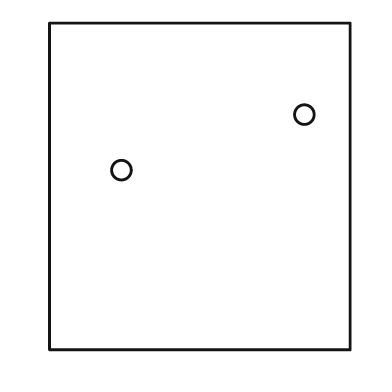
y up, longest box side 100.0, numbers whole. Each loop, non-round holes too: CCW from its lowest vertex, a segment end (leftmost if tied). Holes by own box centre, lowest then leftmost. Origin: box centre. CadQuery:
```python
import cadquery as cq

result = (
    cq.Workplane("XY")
    .moveTo(-46.0, -50.0)
    .lineTo(46.0, -50.0)
    .lineTo(46.0, 50.0)
    .lineTo(-46.0, 50.0)
    .close()
    .moveTo(-24.0, 5.0)
    .circle(3.0)
    .moveTo(32.0, 22.0)
    .circle(3.0)
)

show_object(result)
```